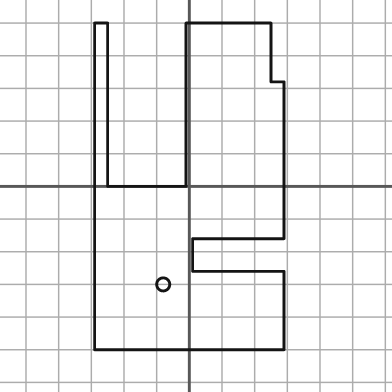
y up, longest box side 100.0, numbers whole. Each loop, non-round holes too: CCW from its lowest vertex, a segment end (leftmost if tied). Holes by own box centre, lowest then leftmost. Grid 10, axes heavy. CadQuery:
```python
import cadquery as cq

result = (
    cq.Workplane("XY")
    .moveTo(-29.0, -50.0)
    .lineTo(29.0, -50.0)
    .lineTo(29.0, -26.0)
    .lineTo(1.0, -26.0)
    .lineTo(1.0, -16.0)
    .lineTo(29.0, -16.0)
    .lineTo(29.0, 32.0)
    .lineTo(25.0, 32.0)
    .lineTo(25.0, 50.0)
    .lineTo(-1.0, 50.0)
    .lineTo(-1.0, 0.0)
    .lineTo(-25.0, 0.0)
    .lineTo(-25.0, 50.0)
    .lineTo(-29.0, 50.0)
    .close()
    .moveTo(-8.0, -30.0)
    .circle(2.0)
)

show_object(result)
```